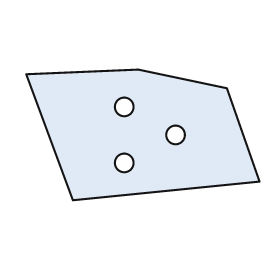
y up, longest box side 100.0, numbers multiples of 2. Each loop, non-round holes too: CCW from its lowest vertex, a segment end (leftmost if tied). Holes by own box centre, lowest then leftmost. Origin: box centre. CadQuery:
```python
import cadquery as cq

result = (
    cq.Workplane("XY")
    .moveTo(-30.0, -28.0)
    .lineTo(50.0, -20.0)
    .lineTo(36.0, 20.0)
    .lineTo(-2.0, 28.0)
    .lineTo(-50.0, 26.0)
    .close()
    .moveTo(-8.0, -12.0)
    .circle(4.0)
    .moveTo(14.0, 0.0)
    .circle(4.0)
    .moveTo(-8.0, 12.0)
    .circle(4.0)
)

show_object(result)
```